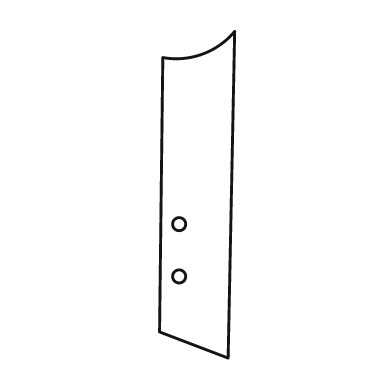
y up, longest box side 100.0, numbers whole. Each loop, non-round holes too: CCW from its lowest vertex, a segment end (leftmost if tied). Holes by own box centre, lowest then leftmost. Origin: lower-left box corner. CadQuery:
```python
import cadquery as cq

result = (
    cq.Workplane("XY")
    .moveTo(21.0, 0.0)
    .lineTo(23.0, 100.0)
    .threePointArc((13.0, 93.0), (1.0, 92.0))
    .lineTo(0.0, 8.0)
    .close()
    .moveTo(6.0, 25.0)
    .circle(2.0)
    .moveTo(6.0, 41.0)
    .circle(2.0)
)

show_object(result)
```